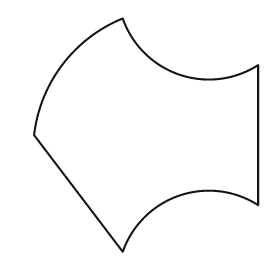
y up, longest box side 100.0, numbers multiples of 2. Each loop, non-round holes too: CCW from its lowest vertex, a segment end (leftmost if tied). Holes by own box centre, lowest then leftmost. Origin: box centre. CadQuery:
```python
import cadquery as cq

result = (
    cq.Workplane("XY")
    .moveTo(-10.0, -50.0)
    .threePointArc((14.0, -26.0), (48.0, -30.0))
    .lineTo(48.0, 30.0)
    .threePointArc((14.0, 26.0), (-10.0, 50.0))
    .threePointArc((-36.0, 30.0), (-48.0, 0.0))
    .close()
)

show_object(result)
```